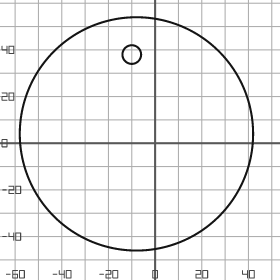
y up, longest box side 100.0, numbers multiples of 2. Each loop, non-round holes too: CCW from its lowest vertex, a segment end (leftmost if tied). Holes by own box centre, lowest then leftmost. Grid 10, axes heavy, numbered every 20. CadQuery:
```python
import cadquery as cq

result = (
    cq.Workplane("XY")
    .moveTo(-8.0, 4.0)
    .circle(50.0)
    .moveTo(-10.0, 38.0)
    .circle(4.0)
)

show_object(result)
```